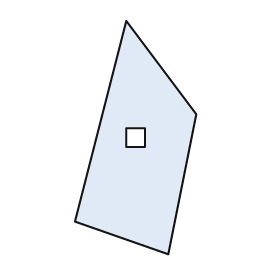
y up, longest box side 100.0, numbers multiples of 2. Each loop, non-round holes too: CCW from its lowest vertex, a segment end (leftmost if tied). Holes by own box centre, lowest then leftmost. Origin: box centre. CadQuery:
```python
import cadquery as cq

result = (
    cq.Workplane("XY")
    .moveTo(14.0, -50.0)
    .lineTo(26.0, 10.0)
    .lineTo(-4.0, 50.0)
    .lineTo(-26.0, -36.0)
    .close()
    .moveTo(-4.0, -4.0)
    .lineTo(4.0, -4.0)
    .lineTo(4.0, 4.0)
    .lineTo(-4.0, 4.0)
    .close()
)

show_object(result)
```